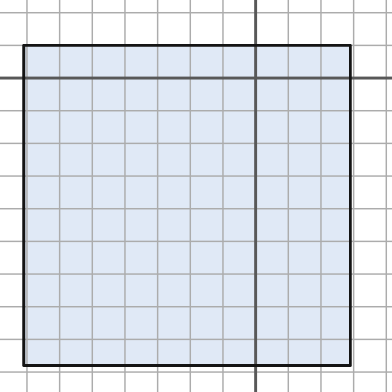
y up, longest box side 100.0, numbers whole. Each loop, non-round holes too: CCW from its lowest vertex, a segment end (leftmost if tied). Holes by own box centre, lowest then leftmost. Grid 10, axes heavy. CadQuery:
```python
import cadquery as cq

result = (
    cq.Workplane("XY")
    .moveTo(-71.0, -88.0)
    .lineTo(29.0, -88.0)
    .lineTo(29.0, 10.0)
    .lineTo(-71.0, 10.0)
    .close()
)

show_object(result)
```